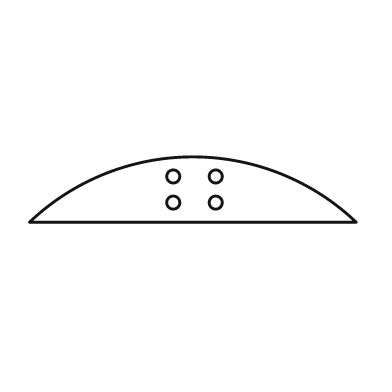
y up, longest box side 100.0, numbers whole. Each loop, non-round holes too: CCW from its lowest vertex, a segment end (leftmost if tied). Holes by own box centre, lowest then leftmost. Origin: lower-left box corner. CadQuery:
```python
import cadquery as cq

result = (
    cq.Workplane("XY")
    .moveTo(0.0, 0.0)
    .lineTo(100.0, 0.0)
    .threePointArc((50.0, 20.0), (0.0, 0.0))
    .close()
    .moveTo(44.0, 6.0)
    .circle(2.0)
    .moveTo(57.0, 6.0)
    .circle(2.0)
    .moveTo(44.0, 14.0)
    .circle(2.0)
    .moveTo(57.0, 14.0)
    .circle(2.0)
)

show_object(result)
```